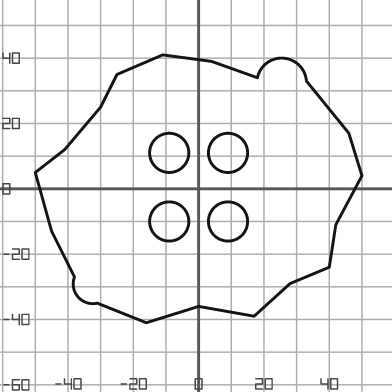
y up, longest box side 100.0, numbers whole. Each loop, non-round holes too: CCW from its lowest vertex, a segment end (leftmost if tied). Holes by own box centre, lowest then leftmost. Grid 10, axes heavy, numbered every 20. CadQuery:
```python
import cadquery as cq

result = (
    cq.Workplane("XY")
    .moveTo(-16.0, -41.0)
    .lineTo(0.0, -36.0)
    .lineTo(17.0, -39.0)
    .lineTo(28.0, -29.0)
    .lineTo(40.0, -24.0)
    .lineTo(42.0, -11.0)
    .lineTo(50.0, 4.0)
    .lineTo(46.0, 17.0)
    .lineTo(33.0, 33.0)
    .threePointArc((26.0, 40.0), (18.0, 34.0))
    .lineTo(4.0, 39.0)
    .lineTo(-11.0, 41.0)
    .lineTo(-25.0, 35.0)
    .lineTo(-30.0, 25.0)
    .lineTo(-41.0, 12.0)
    .lineTo(-50.0, 5.0)
    .lineTo(-45.0, -13.0)
    .lineTo(-38.0, -27.0)
    .threePointArc((-37.0, -33.0), (-31.0, -35.0))
    .close()
    .moveTo(-9.0, -10.0)
    .circle(6.0)
    .moveTo(9.0, -10.0)
    .circle(6.0)
    .moveTo(-9.0, 11.0)
    .circle(6.0)
    .moveTo(9.0, 11.0)
    .circle(6.0)
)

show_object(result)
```